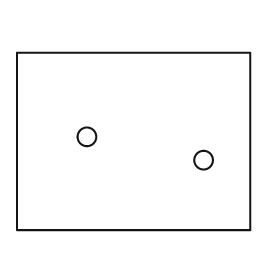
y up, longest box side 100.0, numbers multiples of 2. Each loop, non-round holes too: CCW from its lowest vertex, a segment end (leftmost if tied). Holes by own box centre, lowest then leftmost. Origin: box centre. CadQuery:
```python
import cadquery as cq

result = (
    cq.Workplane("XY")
    .moveTo(-50.0, -38.0)
    .lineTo(50.0, -38.0)
    .lineTo(50.0, 38.0)
    .lineTo(-50.0, 38.0)
    .close()
    .moveTo(30.0, -8.0)
    .circle(4.0)
    .moveTo(-20.0, 2.0)
    .circle(4.0)
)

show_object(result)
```